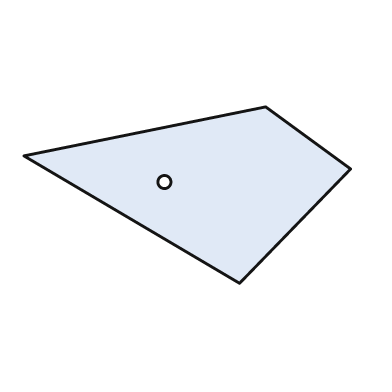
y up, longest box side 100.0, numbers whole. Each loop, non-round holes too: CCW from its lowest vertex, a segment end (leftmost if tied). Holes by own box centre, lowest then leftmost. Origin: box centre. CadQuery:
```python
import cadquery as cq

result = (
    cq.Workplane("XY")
    .moveTo(16.0, -27.0)
    .lineTo(50.0, 8.0)
    .lineTo(24.0, 27.0)
    .lineTo(-50.0, 12.0)
    .close()
    .moveTo(-7.0, 4.0)
    .circle(2.0)
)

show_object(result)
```